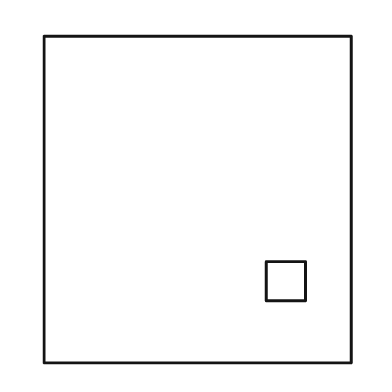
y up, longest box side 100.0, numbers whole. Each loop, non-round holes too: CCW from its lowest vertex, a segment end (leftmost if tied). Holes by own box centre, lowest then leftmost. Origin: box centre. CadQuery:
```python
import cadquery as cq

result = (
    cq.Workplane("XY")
    .moveTo(-47.0, -50.0)
    .lineTo(47.0, -50.0)
    .lineTo(47.0, 50.0)
    .lineTo(-47.0, 50.0)
    .close()
    .moveTo(21.0, -31.0)
    .lineTo(33.0, -31.0)
    .lineTo(33.0, -19.0)
    .lineTo(21.0, -19.0)
    .close()
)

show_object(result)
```